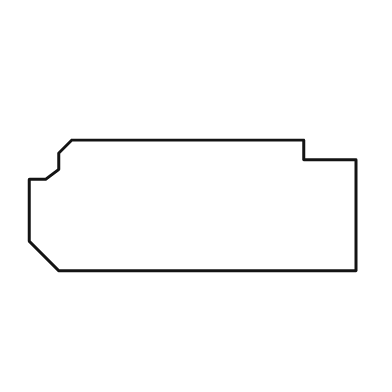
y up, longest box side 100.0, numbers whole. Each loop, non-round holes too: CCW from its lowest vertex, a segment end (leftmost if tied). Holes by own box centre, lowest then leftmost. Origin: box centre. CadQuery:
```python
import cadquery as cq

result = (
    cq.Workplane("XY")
    .moveTo(-41.0, -20.0)
    .lineTo(50.0, -20.0)
    .lineTo(50.0, 14.0)
    .lineTo(34.0, 14.0)
    .lineTo(34.0, 20.0)
    .lineTo(-37.0, 20.0)
    .lineTo(-41.0, 16.0)
    .lineTo(-41.0, 11.0)
    .lineTo(-45.0, 8.0)
    .lineTo(-50.0, 8.0)
    .lineTo(-50.0, -11.0)
    .close()
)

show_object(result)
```